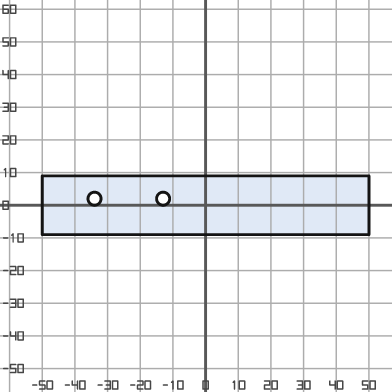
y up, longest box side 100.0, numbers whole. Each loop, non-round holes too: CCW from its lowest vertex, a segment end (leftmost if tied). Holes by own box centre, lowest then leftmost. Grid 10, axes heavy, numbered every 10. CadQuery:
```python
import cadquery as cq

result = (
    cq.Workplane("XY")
    .moveTo(-50.0, -9.0)
    .lineTo(50.0, -9.0)
    .lineTo(50.0, 9.0)
    .lineTo(-50.0, 9.0)
    .close()
    .moveTo(-34.0, 2.0)
    .circle(2.0)
    .moveTo(-13.0, 2.0)
    .circle(2.0)
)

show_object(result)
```